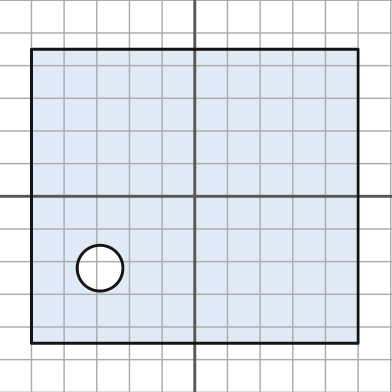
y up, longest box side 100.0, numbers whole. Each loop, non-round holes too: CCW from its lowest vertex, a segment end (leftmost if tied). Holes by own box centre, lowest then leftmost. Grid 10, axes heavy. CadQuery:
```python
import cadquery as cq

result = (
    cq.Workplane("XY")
    .moveTo(-50.0, -45.0)
    .lineTo(50.0, -45.0)
    .lineTo(50.0, 45.0)
    .lineTo(-50.0, 45.0)
    .close()
    .moveTo(-29.0, -22.0)
    .circle(7.0)
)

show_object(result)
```